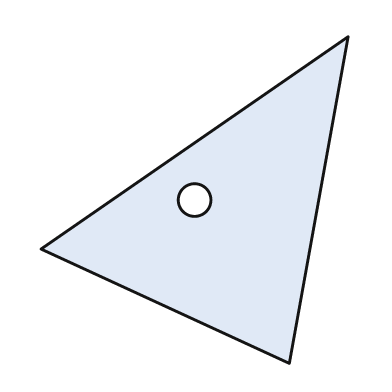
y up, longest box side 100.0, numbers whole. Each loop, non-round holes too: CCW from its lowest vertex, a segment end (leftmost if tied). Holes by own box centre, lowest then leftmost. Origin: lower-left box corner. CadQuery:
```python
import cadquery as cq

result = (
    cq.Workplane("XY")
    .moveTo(76.0, 0.0)
    .lineTo(94.0, 100.0)
    .lineTo(0.0, 35.0)
    .close()
    .moveTo(47.0, 50.0)
    .circle(5.0)
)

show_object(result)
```